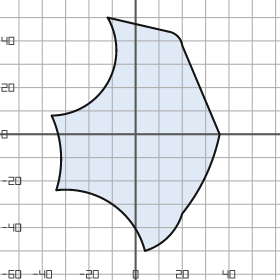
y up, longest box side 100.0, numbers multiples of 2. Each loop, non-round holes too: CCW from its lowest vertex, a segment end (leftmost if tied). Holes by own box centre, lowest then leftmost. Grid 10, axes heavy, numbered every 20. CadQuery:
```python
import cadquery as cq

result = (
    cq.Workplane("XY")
    .moveTo(4.0, -50.0)
    .threePointArc((14.0, -44.0), (20.0, -34.0))
    .threePointArc((30.0, -18.0), (36.0, 0.0))
    .lineTo(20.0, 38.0)
    .threePointArc((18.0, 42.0), (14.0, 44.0))
    .lineTo(-12.0, 50.0)
    .threePointArc((-12.0, 22.0), (-36.0, 8.0))
    .threePointArc((-32.0, -8.0), (-34.0, -24.0))
    .threePointArc((-10.0, -30.0), (4.0, -50.0))
    .close()
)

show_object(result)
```